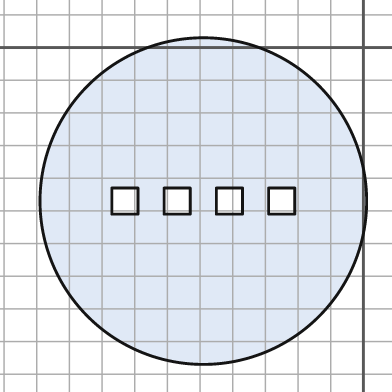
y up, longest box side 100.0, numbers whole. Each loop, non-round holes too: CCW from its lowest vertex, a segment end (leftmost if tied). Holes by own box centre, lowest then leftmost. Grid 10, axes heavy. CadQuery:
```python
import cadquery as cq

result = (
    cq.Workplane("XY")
    .moveTo(-49.0, -47.0)
    .circle(50.0)
    .moveTo(-77.0, -51.0)
    .lineTo(-69.0, -51.0)
    .lineTo(-69.0, -43.0)
    .lineTo(-77.0, -43.0)
    .close()
    .moveTo(-61.0, -51.0)
    .lineTo(-53.0, -51.0)
    .lineTo(-53.0, -43.0)
    .lineTo(-61.0, -43.0)
    .close()
    .moveTo(-45.0, -51.0)
    .lineTo(-37.0, -51.0)
    .lineTo(-37.0, -43.0)
    .lineTo(-45.0, -43.0)
    .close()
    .moveTo(-29.0, -51.0)
    .lineTo(-21.0, -51.0)
    .lineTo(-21.0, -43.0)
    .lineTo(-29.0, -43.0)
    .close()
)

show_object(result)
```